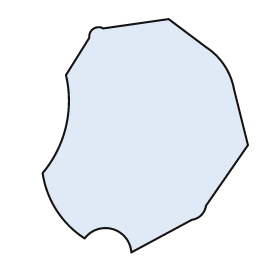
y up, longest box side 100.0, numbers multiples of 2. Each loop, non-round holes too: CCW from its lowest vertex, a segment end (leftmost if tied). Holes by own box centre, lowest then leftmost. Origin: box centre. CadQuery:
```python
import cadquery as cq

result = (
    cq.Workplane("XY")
    .moveTo(-6.0, -50.0)
    .lineTo(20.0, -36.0)
    .threePointArc((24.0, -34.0), (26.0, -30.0))
    .lineTo(44.0, -4.0)
    .lineTo(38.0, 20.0)
    .threePointArc((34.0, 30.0), (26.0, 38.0))
    .lineTo(10.0, 50.0)
    .lineTo(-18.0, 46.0)
    .threePointArc((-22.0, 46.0), (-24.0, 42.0))
    .lineTo(-34.0, 26.0)
    .threePointArc((-34.0, 4.0), (-44.0, -16.0))
    .threePointArc((-38.0, -32.0), (-26.0, -44.0))
    .threePointArc((-14.0, -40.0), (-6.0, -50.0))
    .close()
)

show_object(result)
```